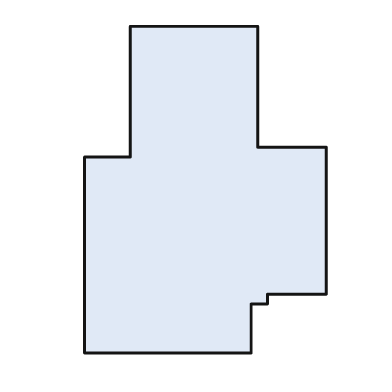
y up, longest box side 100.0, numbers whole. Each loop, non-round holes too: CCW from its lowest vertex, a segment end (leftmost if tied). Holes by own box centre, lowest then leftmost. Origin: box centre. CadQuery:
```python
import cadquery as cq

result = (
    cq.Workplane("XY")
    .moveTo(-37.0, -50.0)
    .lineTo(14.0, -50.0)
    .lineTo(14.0, -35.0)
    .lineTo(19.0, -35.0)
    .lineTo(19.0, -32.0)
    .lineTo(37.0, -32.0)
    .lineTo(37.0, 13.0)
    .lineTo(16.0, 13.0)
    .lineTo(16.0, 50.0)
    .lineTo(-23.0, 50.0)
    .lineTo(-23.0, 10.0)
    .lineTo(-37.0, 10.0)
    .close()
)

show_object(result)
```